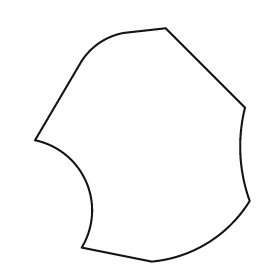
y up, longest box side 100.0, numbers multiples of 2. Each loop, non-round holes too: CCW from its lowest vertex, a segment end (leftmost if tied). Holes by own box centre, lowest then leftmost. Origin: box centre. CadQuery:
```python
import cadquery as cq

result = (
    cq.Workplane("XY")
    .moveTo(4.0, -50.0)
    .threePointArc((28.0, -42.0), (46.0, -24.0))
    .threePointArc((42.0, -4.0), (44.0, 16.0))
    .lineTo(10.0, 50.0)
    .lineTo(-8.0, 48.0)
    .threePointArc((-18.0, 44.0), (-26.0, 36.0))
    .lineTo(-46.0, 2.0)
    .threePointArc((-24.0, -16.0), (-26.0, -44.0))
    .close()
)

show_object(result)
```